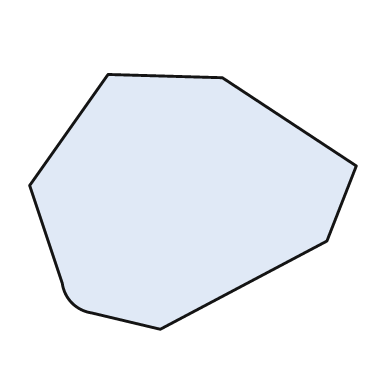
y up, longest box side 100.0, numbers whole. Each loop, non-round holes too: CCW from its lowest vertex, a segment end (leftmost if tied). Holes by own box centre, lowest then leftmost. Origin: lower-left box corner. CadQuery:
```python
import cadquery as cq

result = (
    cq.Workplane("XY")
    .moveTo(40.0, 0.0)
    .lineTo(91.0, 27.0)
    .lineTo(100.0, 50.0)
    .lineTo(59.0, 77.0)
    .lineTo(24.0, 78.0)
    .lineTo(0.0, 44.0)
    .lineTo(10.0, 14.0)
    .threePointArc((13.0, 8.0), (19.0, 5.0))
    .close()
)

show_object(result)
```